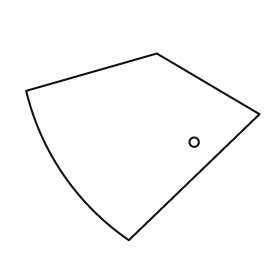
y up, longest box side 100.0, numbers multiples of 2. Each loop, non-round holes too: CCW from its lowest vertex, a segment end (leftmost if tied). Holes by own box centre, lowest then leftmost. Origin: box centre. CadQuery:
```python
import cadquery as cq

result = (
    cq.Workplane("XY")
    .moveTo(-6.0, -40.0)
    .lineTo(50.0, 14.0)
    .lineTo(6.0, 40.0)
    .lineTo(-50.0, 24.0)
    .threePointArc((-34.0, -12.0), (-6.0, -40.0))
    .close()
    .moveTo(22.0, 2.0)
    .circle(2.0)
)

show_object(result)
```